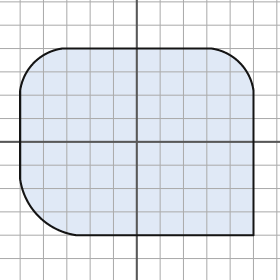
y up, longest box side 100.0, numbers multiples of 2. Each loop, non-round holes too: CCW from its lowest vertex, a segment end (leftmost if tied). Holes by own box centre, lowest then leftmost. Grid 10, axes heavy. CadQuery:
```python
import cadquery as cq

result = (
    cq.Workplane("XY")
    .moveTo(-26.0, -40.0)
    .lineTo(50.0, -40.0)
    .lineTo(50.0, 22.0)
    .threePointArc((44.0, 34.0), (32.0, 40.0))
    .lineTo(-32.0, 40.0)
    .threePointArc((-44.0, 34.0), (-50.0, 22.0))
    .lineTo(-50.0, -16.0)
    .threePointArc((-42.0, -32.0), (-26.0, -40.0))
    .close()
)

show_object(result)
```